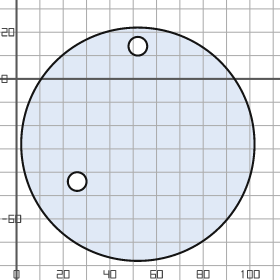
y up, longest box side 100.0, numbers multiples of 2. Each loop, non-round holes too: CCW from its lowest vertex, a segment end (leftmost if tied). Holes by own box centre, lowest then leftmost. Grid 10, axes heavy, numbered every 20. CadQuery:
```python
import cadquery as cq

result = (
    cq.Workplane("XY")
    .moveTo(52.0, -28.0)
    .circle(50.0)
    .moveTo(26.0, -44.0)
    .circle(4.0)
    .moveTo(52.0, 14.0)
    .circle(4.0)
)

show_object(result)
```